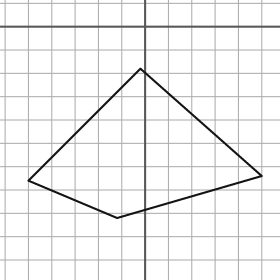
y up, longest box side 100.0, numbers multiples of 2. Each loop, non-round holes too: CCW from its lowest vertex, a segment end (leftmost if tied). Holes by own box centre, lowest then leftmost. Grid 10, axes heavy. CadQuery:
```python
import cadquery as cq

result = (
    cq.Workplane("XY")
    .moveTo(-12.0, -82.0)
    .lineTo(50.0, -64.0)
    .lineTo(-2.0, -18.0)
    .lineTo(-50.0, -66.0)
    .close()
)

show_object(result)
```